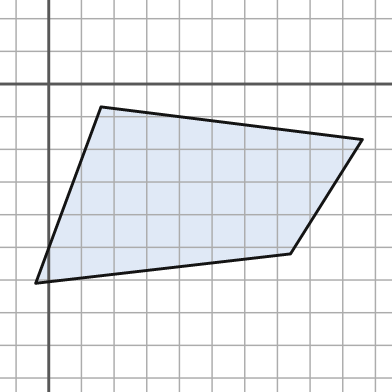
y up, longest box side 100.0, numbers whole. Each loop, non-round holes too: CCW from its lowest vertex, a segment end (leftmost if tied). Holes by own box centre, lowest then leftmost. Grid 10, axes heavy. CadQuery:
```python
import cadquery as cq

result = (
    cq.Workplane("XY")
    .moveTo(-4.0, -61.0)
    .lineTo(74.0, -52.0)
    .lineTo(96.0, -17.0)
    .lineTo(16.0, -7.0)
    .close()
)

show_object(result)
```